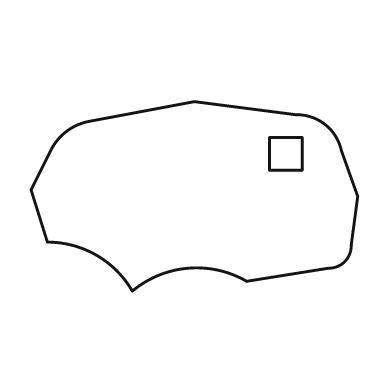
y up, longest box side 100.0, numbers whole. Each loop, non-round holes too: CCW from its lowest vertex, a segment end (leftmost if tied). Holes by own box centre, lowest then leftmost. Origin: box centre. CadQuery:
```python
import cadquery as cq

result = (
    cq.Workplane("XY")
    .moveTo(-19.0, -29.0)
    .threePointArc((-2.0, -22.0), (16.0, -26.0))
    .lineTo(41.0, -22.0)
    .threePointArc((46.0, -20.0), (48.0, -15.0))
    .lineTo(50.0, 0.0)
    .lineTo(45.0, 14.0)
    .threePointArc((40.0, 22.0), (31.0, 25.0))
    .lineTo(0.0, 29.0)
    .lineTo(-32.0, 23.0)
    .threePointArc((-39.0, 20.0), (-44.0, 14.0))
    .lineTo(-50.0, 2.0)
    .lineTo(-45.0, -14.0)
    .threePointArc((-30.0, -18.0), (-19.0, -29.0))
    .close()
    .moveTo(23.0, 8.0)
    .lineTo(33.0, 8.0)
    .lineTo(33.0, 18.0)
    .lineTo(23.0, 18.0)
    .close()
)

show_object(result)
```